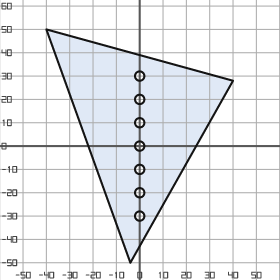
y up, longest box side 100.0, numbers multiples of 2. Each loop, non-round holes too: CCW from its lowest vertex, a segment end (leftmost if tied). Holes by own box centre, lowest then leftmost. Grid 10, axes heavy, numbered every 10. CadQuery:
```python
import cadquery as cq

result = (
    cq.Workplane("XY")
    .moveTo(-4.0, -50.0)
    .lineTo(40.0, 28.0)
    .lineTo(-40.0, 50.0)
    .close()
    .moveTo(0.0, -30.0)
    .circle(2.0)
    .moveTo(0.0, -20.0)
    .circle(2.0)
    .moveTo(0.0, -10.0)
    .circle(2.0)
    .moveTo(0.0, 0.0)
    .circle(2.0)
    .moveTo(0.0, 10.0)
    .circle(2.0)
    .moveTo(0.0, 20.0)
    .circle(2.0)
    .moveTo(0.0, 30.0)
    .circle(2.0)
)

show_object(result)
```